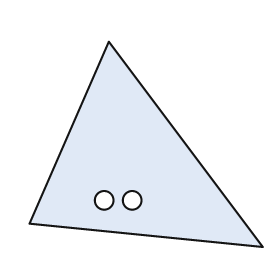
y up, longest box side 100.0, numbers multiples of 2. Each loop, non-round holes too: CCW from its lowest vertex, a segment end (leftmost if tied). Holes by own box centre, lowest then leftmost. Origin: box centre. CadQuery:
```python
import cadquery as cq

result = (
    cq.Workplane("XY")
    .moveTo(50.0, -44.0)
    .lineTo(-16.0, 44.0)
    .lineTo(-50.0, -34.0)
    .close()
    .moveTo(-18.0, -24.0)
    .circle(4.0)
    .moveTo(-6.0, -24.0)
    .circle(4.0)
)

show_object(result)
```